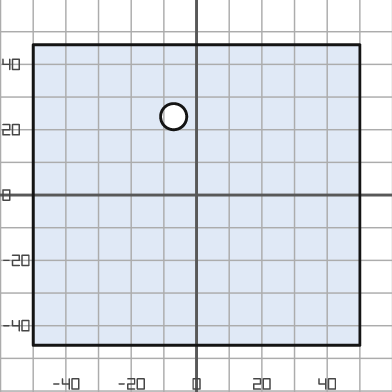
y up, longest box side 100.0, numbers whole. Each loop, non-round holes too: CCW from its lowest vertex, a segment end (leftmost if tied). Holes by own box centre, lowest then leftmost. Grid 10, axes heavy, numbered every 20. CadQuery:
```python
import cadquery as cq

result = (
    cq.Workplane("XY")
    .moveTo(-50.0, -46.0)
    .lineTo(50.0, -46.0)
    .lineTo(50.0, 46.0)
    .lineTo(-50.0, 46.0)
    .close()
    .moveTo(-7.0, 24.0)
    .circle(4.0)
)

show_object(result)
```